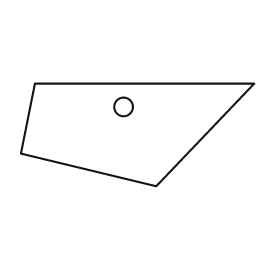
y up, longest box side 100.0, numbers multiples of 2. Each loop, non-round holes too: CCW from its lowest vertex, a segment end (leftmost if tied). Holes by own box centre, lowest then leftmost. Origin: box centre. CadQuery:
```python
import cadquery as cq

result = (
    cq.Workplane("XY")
    .moveTo(8.0, -22.0)
    .lineTo(50.0, 22.0)
    .lineTo(-44.0, 22.0)
    .lineTo(-50.0, -8.0)
    .close()
    .moveTo(-6.0, 12.0)
    .circle(4.0)
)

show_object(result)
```